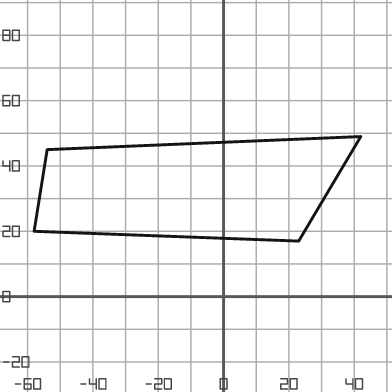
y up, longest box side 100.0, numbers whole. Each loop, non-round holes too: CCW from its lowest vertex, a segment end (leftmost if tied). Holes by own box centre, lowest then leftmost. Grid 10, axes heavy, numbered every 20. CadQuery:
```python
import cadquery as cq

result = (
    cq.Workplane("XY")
    .moveTo(23.0, 17.0)
    .lineTo(42.0, 49.0)
    .lineTo(-54.0, 45.0)
    .lineTo(-58.0, 20.0)
    .close()
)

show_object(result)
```